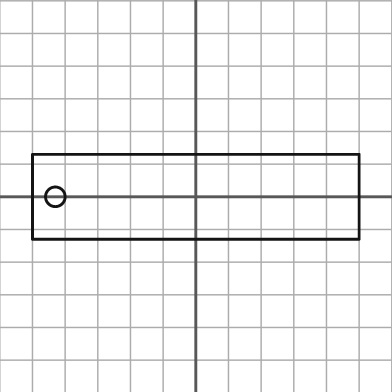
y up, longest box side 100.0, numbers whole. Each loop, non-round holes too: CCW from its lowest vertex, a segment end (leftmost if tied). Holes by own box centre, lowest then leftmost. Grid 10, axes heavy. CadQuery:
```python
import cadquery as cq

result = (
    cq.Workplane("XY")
    .moveTo(-50.0, -13.0)
    .lineTo(50.0, -13.0)
    .lineTo(50.0, 13.0)
    .lineTo(-50.0, 13.0)
    .close()
    .moveTo(-43.0, 0.0)
    .circle(3.0)
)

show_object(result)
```